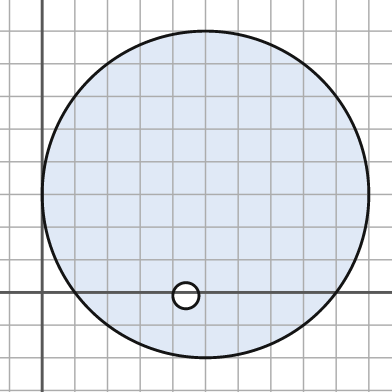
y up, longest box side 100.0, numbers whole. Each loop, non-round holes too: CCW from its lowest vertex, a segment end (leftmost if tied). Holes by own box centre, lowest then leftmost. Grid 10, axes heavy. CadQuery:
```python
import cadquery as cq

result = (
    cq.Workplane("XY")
    .moveTo(50.0, 30.0)
    .circle(50.0)
    .moveTo(44.0, -1.0)
    .circle(4.0)
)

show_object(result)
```